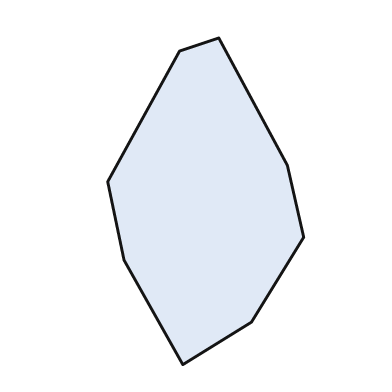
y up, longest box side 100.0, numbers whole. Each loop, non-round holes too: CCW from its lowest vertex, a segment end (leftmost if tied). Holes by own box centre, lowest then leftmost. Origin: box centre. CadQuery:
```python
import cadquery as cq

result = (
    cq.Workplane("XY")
    .moveTo(-7.0, -50.0)
    .lineTo(14.0, -37.0)
    .lineTo(30.0, -11.0)
    .lineTo(25.0, 11.0)
    .lineTo(4.0, 50.0)
    .lineTo(-8.0, 46.0)
    .lineTo(-30.0, 6.0)
    .lineTo(-25.0, -18.0)
    .close()
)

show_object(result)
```